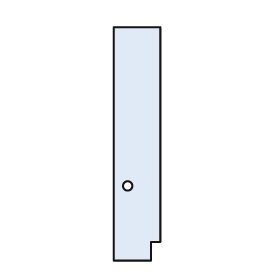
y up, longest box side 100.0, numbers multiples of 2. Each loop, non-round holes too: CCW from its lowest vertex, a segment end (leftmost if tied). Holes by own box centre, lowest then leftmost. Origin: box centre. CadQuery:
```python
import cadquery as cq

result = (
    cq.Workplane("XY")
    .moveTo(-10.0, -50.0)
    .lineTo(6.0, -50.0)
    .lineTo(6.0, -42.0)
    .lineTo(10.0, -42.0)
    .lineTo(10.0, 50.0)
    .lineTo(-10.0, 50.0)
    .close()
    .moveTo(-4.0, -18.0)
    .circle(2.0)
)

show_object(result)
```